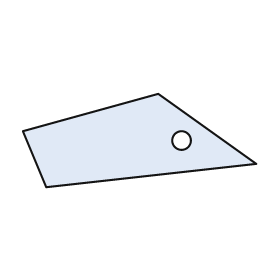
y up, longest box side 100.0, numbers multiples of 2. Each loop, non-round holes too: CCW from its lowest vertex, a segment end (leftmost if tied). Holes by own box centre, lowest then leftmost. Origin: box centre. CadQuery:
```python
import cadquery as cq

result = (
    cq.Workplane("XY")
    .moveTo(-40.0, -20.0)
    .lineTo(50.0, -10.0)
    .lineTo(8.0, 20.0)
    .lineTo(-50.0, 4.0)
    .close()
    .moveTo(18.0, 0.0)
    .circle(4.0)
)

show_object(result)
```